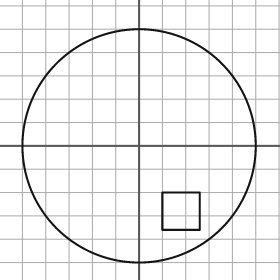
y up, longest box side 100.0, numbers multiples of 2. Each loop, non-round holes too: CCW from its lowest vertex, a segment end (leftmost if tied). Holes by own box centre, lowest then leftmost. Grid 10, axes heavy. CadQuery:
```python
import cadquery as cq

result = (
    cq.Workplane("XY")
    .moveTo(0.0, 0.0)
    .circle(50.0)
    .moveTo(10.0, -36.0)
    .lineTo(26.0, -36.0)
    .lineTo(26.0, -20.0)
    .lineTo(10.0, -20.0)
    .close()
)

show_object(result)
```